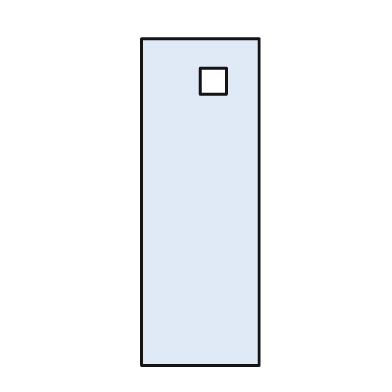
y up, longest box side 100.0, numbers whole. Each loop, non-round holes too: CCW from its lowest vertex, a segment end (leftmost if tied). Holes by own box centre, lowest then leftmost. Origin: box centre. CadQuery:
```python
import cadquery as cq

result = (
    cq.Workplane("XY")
    .moveTo(-18.0, -50.0)
    .lineTo(18.0, -50.0)
    .lineTo(18.0, 50.0)
    .lineTo(-18.0, 50.0)
    .close()
    .moveTo(0.0, 33.0)
    .lineTo(8.0, 33.0)
    .lineTo(8.0, 41.0)
    .lineTo(0.0, 41.0)
    .close()
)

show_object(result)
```